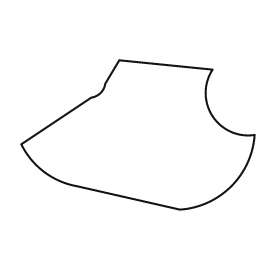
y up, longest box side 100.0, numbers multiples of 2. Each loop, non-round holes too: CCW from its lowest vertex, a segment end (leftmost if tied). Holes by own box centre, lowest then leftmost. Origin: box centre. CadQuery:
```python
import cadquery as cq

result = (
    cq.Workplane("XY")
    .moveTo(18.0, -32.0)
    .threePointArc((40.0, -22.0), (50.0, 0.0))
    .threePointArc((32.0, 8.0), (32.0, 28.0))
    .lineTo(-8.0, 32.0)
    .lineTo(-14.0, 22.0)
    .threePointArc((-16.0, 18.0), (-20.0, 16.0))
    .lineTo(-50.0, -4.0)
    .threePointArc((-40.0, -16.0), (-26.0, -22.0))
    .close()
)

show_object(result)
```